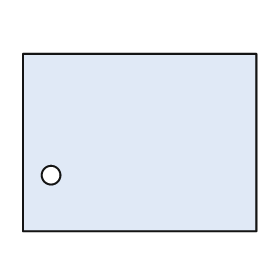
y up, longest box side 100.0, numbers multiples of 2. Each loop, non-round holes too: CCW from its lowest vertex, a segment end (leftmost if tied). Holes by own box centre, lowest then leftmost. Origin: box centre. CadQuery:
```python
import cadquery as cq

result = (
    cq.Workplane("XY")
    .moveTo(-50.0, -38.0)
    .lineTo(50.0, -38.0)
    .lineTo(50.0, 38.0)
    .lineTo(-50.0, 38.0)
    .close()
    .moveTo(-38.0, -14.0)
    .circle(4.0)
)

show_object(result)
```